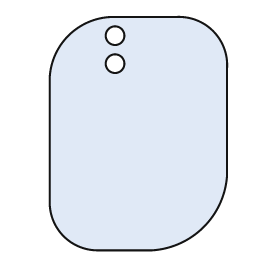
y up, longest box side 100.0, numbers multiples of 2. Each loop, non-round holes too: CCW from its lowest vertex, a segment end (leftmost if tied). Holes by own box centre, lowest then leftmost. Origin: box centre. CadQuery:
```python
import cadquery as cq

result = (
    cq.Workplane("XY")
    .moveTo(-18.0, -50.0)
    .lineTo(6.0, -50.0)
    .threePointArc((28.0, -40.0), (38.0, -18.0))
    .lineTo(38.0, 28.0)
    .threePointArc((32.0, 44.0), (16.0, 50.0))
    .lineTo(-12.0, 50.0)
    .threePointArc((-30.0, 42.0), (-38.0, 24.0))
    .lineTo(-38.0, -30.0)
    .threePointArc((-32.0, -44.0), (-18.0, -50.0))
    .close()
    .moveTo(-10.0, 30.0)
    .circle(4.0)
    .moveTo(-10.0, 42.0)
    .circle(4.0)
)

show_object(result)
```